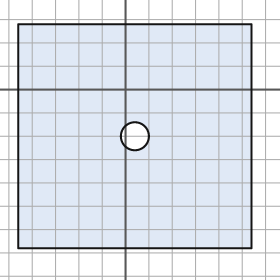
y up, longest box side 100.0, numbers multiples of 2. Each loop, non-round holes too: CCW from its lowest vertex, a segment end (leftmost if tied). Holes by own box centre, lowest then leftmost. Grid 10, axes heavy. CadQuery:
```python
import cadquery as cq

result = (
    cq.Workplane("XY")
    .moveTo(-46.0, -68.0)
    .lineTo(54.0, -68.0)
    .lineTo(54.0, 28.0)
    .lineTo(-46.0, 28.0)
    .close()
    .moveTo(4.0, -20.0)
    .circle(6.0)
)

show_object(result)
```